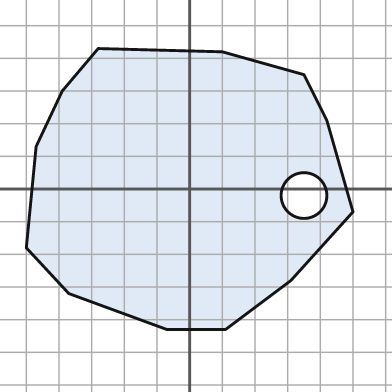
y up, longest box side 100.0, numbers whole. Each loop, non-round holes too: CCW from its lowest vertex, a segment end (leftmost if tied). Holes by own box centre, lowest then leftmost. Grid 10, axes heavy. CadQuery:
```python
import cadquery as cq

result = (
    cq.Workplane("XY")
    .moveTo(-7.0, -43.0)
    .lineTo(11.0, -43.0)
    .lineTo(31.0, -28.0)
    .lineTo(50.0, -7.0)
    .lineTo(42.0, 21.0)
    .lineTo(35.0, 35.0)
    .lineTo(10.0, 42.0)
    .lineTo(-28.0, 43.0)
    .lineTo(-39.0, 30.0)
    .lineTo(-47.0, 13.0)
    .lineTo(-50.0, -18.0)
    .lineTo(-37.0, -32.0)
    .close()
    .moveTo(35.0, -2.0)
    .circle(7.0)
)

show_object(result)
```